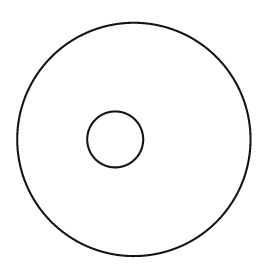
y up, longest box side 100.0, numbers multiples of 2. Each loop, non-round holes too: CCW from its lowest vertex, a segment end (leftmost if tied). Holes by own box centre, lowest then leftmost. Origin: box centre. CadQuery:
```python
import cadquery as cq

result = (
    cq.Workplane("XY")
    .moveTo(0.0, 0.0)
    .circle(50.0)
    .moveTo(-8.0, 0.0)
    .circle(12.0)
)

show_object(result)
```